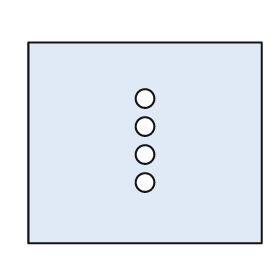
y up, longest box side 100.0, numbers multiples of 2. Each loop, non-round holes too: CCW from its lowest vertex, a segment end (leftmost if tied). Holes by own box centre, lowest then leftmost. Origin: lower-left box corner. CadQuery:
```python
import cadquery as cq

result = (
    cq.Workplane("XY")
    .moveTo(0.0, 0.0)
    .lineTo(100.0, 0.0)
    .lineTo(100.0, 86.0)
    .lineTo(0.0, 86.0)
    .close()
    .moveTo(50.0, 26.0)
    .circle(4.0)
    .moveTo(50.0, 38.0)
    .circle(4.0)
    .moveTo(50.0, 50.0)
    .circle(4.0)
    .moveTo(50.0, 62.0)
    .circle(4.0)
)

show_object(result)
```